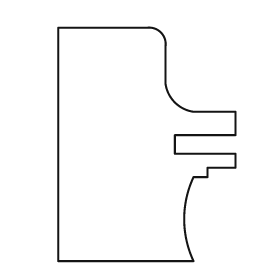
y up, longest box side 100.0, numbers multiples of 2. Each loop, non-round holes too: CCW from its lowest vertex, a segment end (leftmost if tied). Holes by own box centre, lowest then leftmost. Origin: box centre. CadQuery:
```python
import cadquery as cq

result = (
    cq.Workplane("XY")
    .moveTo(-38.0, -50.0)
    .lineTo(20.0, -50.0)
    .threePointArc((16.0, -32.0), (20.0, -14.0))
    .lineTo(26.0, -14.0)
    .lineTo(26.0, -10.0)
    .lineTo(38.0, -10.0)
    .lineTo(38.0, -4.0)
    .lineTo(12.0, -4.0)
    .lineTo(12.0, 4.0)
    .lineTo(38.0, 4.0)
    .lineTo(38.0, 14.0)
    .lineTo(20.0, 14.0)
    .threePointArc((12.0, 18.0), (8.0, 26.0))
    .lineTo(8.0, 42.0)
    .threePointArc((6.0, 48.0), (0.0, 50.0))
    .lineTo(-38.0, 50.0)
    .close()
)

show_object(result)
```